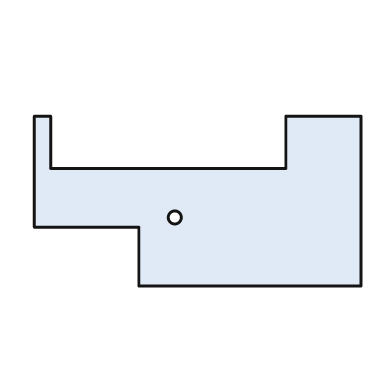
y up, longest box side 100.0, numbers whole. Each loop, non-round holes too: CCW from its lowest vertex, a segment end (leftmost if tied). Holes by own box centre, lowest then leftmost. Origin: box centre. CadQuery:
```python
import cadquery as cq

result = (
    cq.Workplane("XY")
    .moveTo(-18.0, -26.0)
    .lineTo(50.0, -26.0)
    .lineTo(50.0, 26.0)
    .lineTo(27.0, 26.0)
    .lineTo(27.0, 10.0)
    .lineTo(-45.0, 10.0)
    .lineTo(-45.0, 26.0)
    .lineTo(-50.0, 26.0)
    .lineTo(-50.0, -8.0)
    .lineTo(-18.0, -8.0)
    .close()
    .moveTo(-7.0, -5.0)
    .circle(2.0)
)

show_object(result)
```